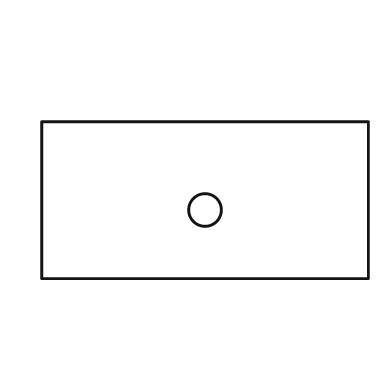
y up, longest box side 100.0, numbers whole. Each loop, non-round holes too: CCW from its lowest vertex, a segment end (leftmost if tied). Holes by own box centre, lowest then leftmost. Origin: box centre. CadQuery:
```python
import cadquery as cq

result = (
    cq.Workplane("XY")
    .moveTo(-50.0, -24.0)
    .lineTo(50.0, -24.0)
    .lineTo(50.0, 24.0)
    .lineTo(-50.0, 24.0)
    .close()
    .moveTo(0.0, -3.0)
    .circle(5.0)
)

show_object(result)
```